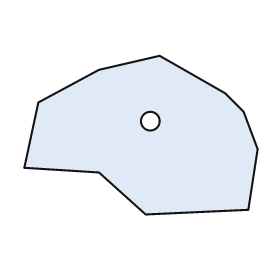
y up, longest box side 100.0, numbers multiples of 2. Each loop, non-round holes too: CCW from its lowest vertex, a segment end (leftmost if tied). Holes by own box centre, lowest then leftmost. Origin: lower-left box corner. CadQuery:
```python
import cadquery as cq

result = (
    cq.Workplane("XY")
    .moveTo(52.0, 0.0)
    .lineTo(96.0, 2.0)
    .lineTo(100.0, 28.0)
    .lineTo(94.0, 44.0)
    .lineTo(86.0, 52.0)
    .lineTo(58.0, 68.0)
    .lineTo(32.0, 62.0)
    .lineTo(6.0, 48.0)
    .lineTo(0.0, 20.0)
    .lineTo(32.0, 18.0)
    .close()
    .moveTo(54.0, 40.0)
    .circle(4.0)
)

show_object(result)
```